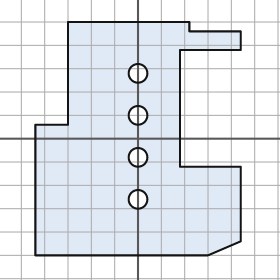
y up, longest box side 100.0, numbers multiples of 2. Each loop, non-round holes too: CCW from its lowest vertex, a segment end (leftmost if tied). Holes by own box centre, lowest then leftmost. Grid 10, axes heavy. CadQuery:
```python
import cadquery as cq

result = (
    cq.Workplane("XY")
    .moveTo(-44.0, -50.0)
    .lineTo(30.0, -50.0)
    .lineTo(44.0, -44.0)
    .lineTo(44.0, -12.0)
    .lineTo(18.0, -12.0)
    .lineTo(18.0, 38.0)
    .lineTo(44.0, 38.0)
    .lineTo(44.0, 46.0)
    .lineTo(22.0, 46.0)
    .lineTo(22.0, 50.0)
    .lineTo(-30.0, 50.0)
    .lineTo(-30.0, 6.0)
    .lineTo(-44.0, 6.0)
    .close()
    .moveTo(0.0, -26.0)
    .circle(4.0)
    .moveTo(0.0, -8.0)
    .circle(4.0)
    .moveTo(0.0, 10.0)
    .circle(4.0)
    .moveTo(0.0, 28.0)
    .circle(4.0)
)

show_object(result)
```